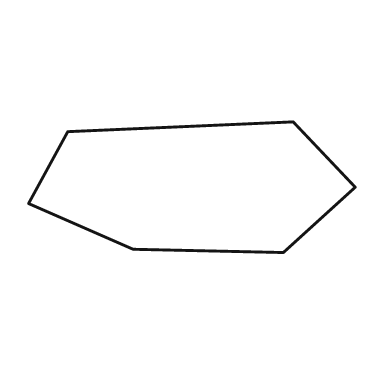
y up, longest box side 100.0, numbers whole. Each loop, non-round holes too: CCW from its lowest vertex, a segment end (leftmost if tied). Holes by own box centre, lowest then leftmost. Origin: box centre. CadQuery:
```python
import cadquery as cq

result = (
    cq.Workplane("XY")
    .moveTo(28.0, -20.0)
    .lineTo(50.0, 0.0)
    .lineTo(31.0, 20.0)
    .lineTo(-38.0, 17.0)
    .lineTo(-50.0, -5.0)
    .lineTo(-18.0, -19.0)
    .close()
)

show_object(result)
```